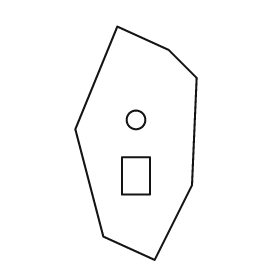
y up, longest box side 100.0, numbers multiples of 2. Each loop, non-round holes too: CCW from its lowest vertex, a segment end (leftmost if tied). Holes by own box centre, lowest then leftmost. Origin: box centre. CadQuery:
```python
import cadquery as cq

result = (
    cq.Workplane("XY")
    .moveTo(8.0, -50.0)
    .lineTo(24.0, -18.0)
    .lineTo(26.0, 28.0)
    .lineTo(14.0, 40.0)
    .lineTo(-8.0, 50.0)
    .lineTo(-26.0, 6.0)
    .lineTo(-14.0, -40.0)
    .close()
    .moveTo(-6.0, -22.0)
    .lineTo(6.0, -22.0)
    .lineTo(6.0, -6.0)
    .lineTo(-6.0, -6.0)
    .close()
    .moveTo(0.0, 10.0)
    .circle(4.0)
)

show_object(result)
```